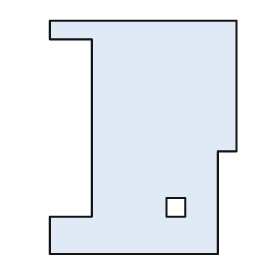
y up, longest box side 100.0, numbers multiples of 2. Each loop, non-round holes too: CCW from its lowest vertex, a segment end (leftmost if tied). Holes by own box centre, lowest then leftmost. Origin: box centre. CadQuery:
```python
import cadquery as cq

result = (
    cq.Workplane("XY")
    .moveTo(-40.0, -50.0)
    .lineTo(32.0, -50.0)
    .lineTo(32.0, -6.0)
    .lineTo(40.0, -6.0)
    .lineTo(40.0, 50.0)
    .lineTo(-40.0, 50.0)
    .lineTo(-40.0, 42.0)
    .lineTo(-22.0, 42.0)
    .lineTo(-22.0, -34.0)
    .lineTo(-40.0, -34.0)
    .close()
    .moveTo(10.0, -34.0)
    .lineTo(18.0, -34.0)
    .lineTo(18.0, -26.0)
    .lineTo(10.0, -26.0)
    .close()
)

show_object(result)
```